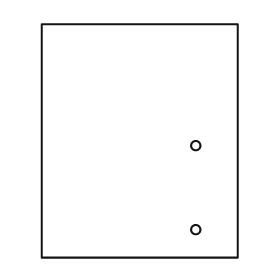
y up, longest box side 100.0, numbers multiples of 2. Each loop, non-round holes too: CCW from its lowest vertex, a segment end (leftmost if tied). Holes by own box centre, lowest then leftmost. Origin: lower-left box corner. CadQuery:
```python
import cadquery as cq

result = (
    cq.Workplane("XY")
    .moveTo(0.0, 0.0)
    .lineTo(84.0, 0.0)
    .lineTo(84.0, 100.0)
    .lineTo(0.0, 100.0)
    .close()
    .moveTo(66.0, 12.0)
    .circle(2.0)
    .moveTo(66.0, 48.0)
    .circle(2.0)
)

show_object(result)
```